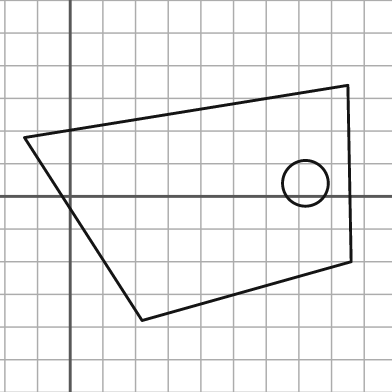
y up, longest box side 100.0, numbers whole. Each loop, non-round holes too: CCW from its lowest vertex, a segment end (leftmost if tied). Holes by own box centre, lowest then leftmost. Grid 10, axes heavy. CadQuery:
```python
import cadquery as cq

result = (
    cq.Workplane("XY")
    .moveTo(22.0, -38.0)
    .lineTo(86.0, -20.0)
    .lineTo(85.0, 34.0)
    .lineTo(-14.0, 18.0)
    .close()
    .moveTo(72.0, 4.0)
    .circle(7.0)
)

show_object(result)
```